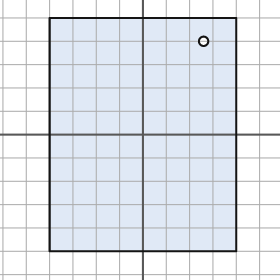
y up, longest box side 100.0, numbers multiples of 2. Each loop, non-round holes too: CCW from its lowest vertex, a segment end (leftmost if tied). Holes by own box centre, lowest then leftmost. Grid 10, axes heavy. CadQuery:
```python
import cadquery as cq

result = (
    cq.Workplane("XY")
    .moveTo(-40.0, -50.0)
    .lineTo(40.0, -50.0)
    .lineTo(40.0, 50.0)
    .lineTo(-40.0, 50.0)
    .close()
    .moveTo(26.0, 40.0)
    .circle(2.0)
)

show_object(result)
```